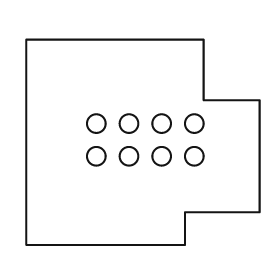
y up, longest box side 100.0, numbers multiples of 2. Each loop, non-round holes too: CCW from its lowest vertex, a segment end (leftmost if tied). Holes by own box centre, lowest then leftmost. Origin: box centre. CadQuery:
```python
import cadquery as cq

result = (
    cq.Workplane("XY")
    .moveTo(-50.0, -44.0)
    .lineTo(18.0, -44.0)
    .lineTo(18.0, -30.0)
    .lineTo(50.0, -30.0)
    .lineTo(50.0, 18.0)
    .lineTo(26.0, 18.0)
    .lineTo(26.0, 44.0)
    .lineTo(-50.0, 44.0)
    .close()
    .moveTo(-20.0, -6.0)
    .circle(4.0)
    .moveTo(-6.0, -6.0)
    .circle(4.0)
    .moveTo(8.0, -6.0)
    .circle(4.0)
    .moveTo(22.0, -6.0)
    .circle(4.0)
    .moveTo(-20.0, 8.0)
    .circle(4.0)
    .moveTo(-6.0, 8.0)
    .circle(4.0)
    .moveTo(8.0, 8.0)
    .circle(4.0)
    .moveTo(22.0, 8.0)
    .circle(4.0)
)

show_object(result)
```